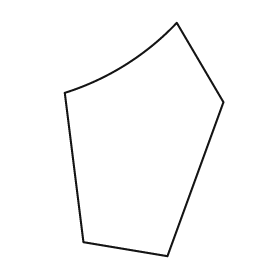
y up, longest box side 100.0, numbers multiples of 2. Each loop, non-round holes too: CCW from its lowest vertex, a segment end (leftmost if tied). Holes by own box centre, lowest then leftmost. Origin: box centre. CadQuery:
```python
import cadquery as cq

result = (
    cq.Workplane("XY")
    .moveTo(10.0, -50.0)
    .lineTo(34.0, 16.0)
    .lineTo(14.0, 50.0)
    .threePointArc((-8.0, 32.0), (-34.0, 20.0))
    .lineTo(-26.0, -44.0)
    .close()
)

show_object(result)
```